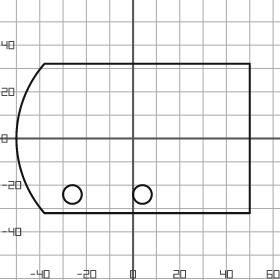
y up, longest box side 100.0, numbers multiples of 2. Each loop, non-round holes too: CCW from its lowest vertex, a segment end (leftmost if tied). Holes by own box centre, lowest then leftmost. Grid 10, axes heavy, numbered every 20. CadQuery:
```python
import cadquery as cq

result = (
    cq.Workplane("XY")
    .moveTo(-38.0, -32.0)
    .lineTo(50.0, -32.0)
    .lineTo(50.0, 32.0)
    .lineTo(-38.0, 32.0)
    .threePointArc((-50.0, 0.0), (-38.0, -32.0))
    .close()
    .moveTo(-26.0, -24.0)
    .circle(4.0)
    .moveTo(4.0, -24.0)
    .circle(4.0)
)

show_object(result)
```